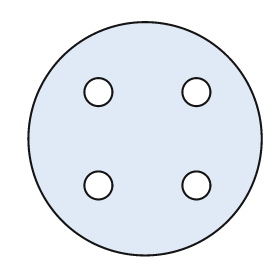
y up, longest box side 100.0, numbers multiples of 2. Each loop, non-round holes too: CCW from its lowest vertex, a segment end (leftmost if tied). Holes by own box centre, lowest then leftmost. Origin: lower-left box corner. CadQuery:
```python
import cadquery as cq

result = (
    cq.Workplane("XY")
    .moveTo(50.0, 50.0)
    .circle(50.0)
    .moveTo(30.0, 30.0)
    .circle(6.0)
    .moveTo(72.0, 30.0)
    .circle(6.0)
    .moveTo(30.0, 70.0)
    .circle(6.0)
    .moveTo(72.0, 70.0)
    .circle(6.0)
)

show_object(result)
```